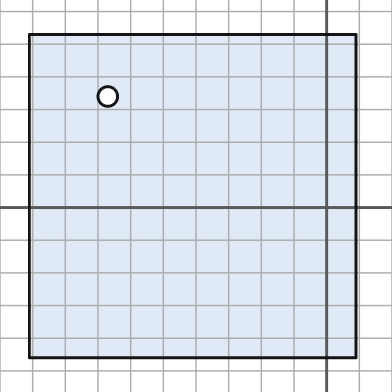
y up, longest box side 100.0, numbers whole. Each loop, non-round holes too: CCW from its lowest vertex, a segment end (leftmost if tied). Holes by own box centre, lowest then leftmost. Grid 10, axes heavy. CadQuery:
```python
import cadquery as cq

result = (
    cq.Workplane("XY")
    .moveTo(-91.0, -46.0)
    .lineTo(9.0, -46.0)
    .lineTo(9.0, 53.0)
    .lineTo(-91.0, 53.0)
    .close()
    .moveTo(-67.0, 34.0)
    .circle(3.0)
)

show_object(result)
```